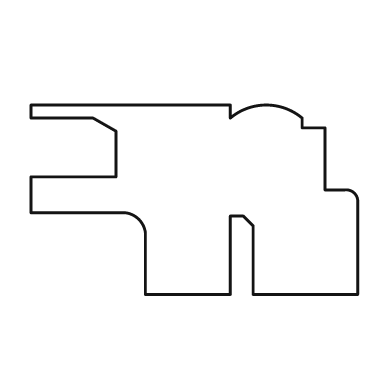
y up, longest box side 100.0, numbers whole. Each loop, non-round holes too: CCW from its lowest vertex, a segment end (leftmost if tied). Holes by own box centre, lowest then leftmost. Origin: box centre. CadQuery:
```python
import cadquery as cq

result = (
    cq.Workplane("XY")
    .moveTo(-15.0, -29.0)
    .lineTo(11.0, -29.0)
    .lineTo(11.0, -5.0)
    .lineTo(15.0, -5.0)
    .lineTo(18.0, -8.0)
    .lineTo(18.0, -29.0)
    .lineTo(50.0, -29.0)
    .lineTo(50.0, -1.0)
    .threePointArc((49.0, 2.0), (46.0, 3.0))
    .lineTo(40.0, 3.0)
    .lineTo(40.0, 22.0)
    .lineTo(33.0, 22.0)
    .lineTo(33.0, 25.0)
    .threePointArc((22.0, 29.0), (11.0, 25.0))
    .lineTo(11.0, 29.0)
    .lineTo(-50.0, 29.0)
    .lineTo(-50.0, 25.0)
    .lineTo(-31.0, 25.0)
    .lineTo(-24.0, 21.0)
    .lineTo(-24.0, 7.0)
    .lineTo(-50.0, 7.0)
    .lineTo(-50.0, -4.0)
    .lineTo(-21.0, -4.0)
    .threePointArc((-17.0, -6.0), (-15.0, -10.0))
    .close()
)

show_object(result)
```